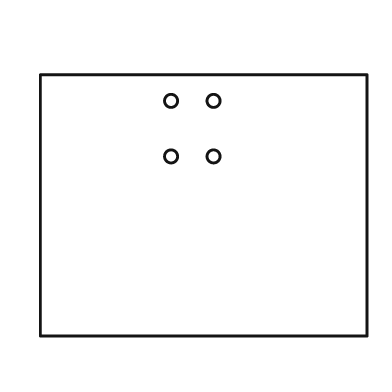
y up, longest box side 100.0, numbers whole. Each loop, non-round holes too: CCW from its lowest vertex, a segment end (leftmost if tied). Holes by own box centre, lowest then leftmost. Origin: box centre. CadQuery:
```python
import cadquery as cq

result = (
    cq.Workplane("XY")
    .moveTo(-50.0, -40.0)
    .lineTo(50.0, -40.0)
    .lineTo(50.0, 40.0)
    .lineTo(-50.0, 40.0)
    .close()
    .moveTo(-10.0, 15.0)
    .circle(2.0)
    .moveTo(3.0, 15.0)
    .circle(2.0)
    .moveTo(-10.0, 32.0)
    .circle(2.0)
    .moveTo(3.0, 32.0)
    .circle(2.0)
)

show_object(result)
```